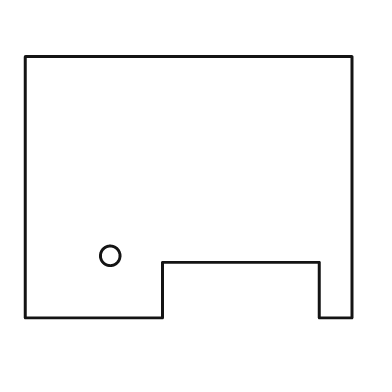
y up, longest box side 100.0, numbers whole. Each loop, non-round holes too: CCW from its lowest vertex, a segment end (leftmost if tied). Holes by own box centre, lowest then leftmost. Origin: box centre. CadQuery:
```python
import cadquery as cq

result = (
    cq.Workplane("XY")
    .moveTo(-50.0, -40.0)
    .lineTo(-8.0, -40.0)
    .lineTo(-8.0, -23.0)
    .lineTo(40.0, -23.0)
    .lineTo(40.0, -40.0)
    .lineTo(50.0, -40.0)
    .lineTo(50.0, 40.0)
    .lineTo(-50.0, 40.0)
    .close()
    .moveTo(-24.0, -21.0)
    .circle(3.0)
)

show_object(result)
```